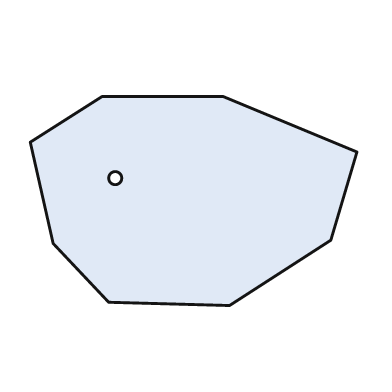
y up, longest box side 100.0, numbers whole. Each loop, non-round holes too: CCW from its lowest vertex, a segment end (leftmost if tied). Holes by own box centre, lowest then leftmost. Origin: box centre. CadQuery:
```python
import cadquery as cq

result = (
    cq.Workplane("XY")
    .moveTo(11.0, -32.0)
    .lineTo(42.0, -12.0)
    .lineTo(50.0, 15.0)
    .lineTo(9.0, 32.0)
    .lineTo(-28.0, 32.0)
    .lineTo(-50.0, 18.0)
    .lineTo(-43.0, -13.0)
    .lineTo(-26.0, -31.0)
    .close()
    .moveTo(-24.0, 7.0)
    .circle(2.0)
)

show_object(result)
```